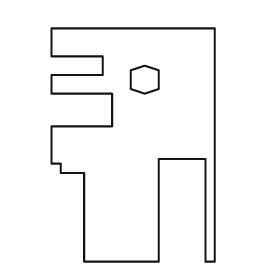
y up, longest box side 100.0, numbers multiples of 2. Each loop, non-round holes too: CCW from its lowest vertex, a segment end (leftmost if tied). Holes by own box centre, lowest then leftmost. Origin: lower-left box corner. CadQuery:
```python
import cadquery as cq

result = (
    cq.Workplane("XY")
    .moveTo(14.0, 0.0)
    .lineTo(46.0, 0.0)
    .lineTo(46.0, 44.0)
    .lineTo(66.0, 44.0)
    .lineTo(66.0, 0.0)
    .lineTo(70.0, 0.0)
    .lineTo(70.0, 100.0)
    .lineTo(0.0, 100.0)
    .lineTo(0.0, 88.0)
    .lineTo(22.0, 88.0)
    .lineTo(22.0, 80.0)
    .lineTo(0.0, 80.0)
    .lineTo(0.0, 72.0)
    .lineTo(26.0, 72.0)
    .lineTo(26.0, 58.0)
    .lineTo(0.0, 58.0)
    .lineTo(0.0, 42.0)
    .lineTo(4.0, 42.0)
    .lineTo(4.0, 38.0)
    .lineTo(14.0, 38.0)
    .close()
    .moveTo(40.0, 72.0)
    .lineTo(46.0, 74.0)
    .lineTo(46.0, 82.0)
    .lineTo(40.0, 84.0)
    .lineTo(34.0, 82.0)
    .lineTo(34.0, 74.0)
    .close()
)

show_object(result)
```